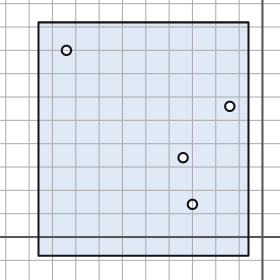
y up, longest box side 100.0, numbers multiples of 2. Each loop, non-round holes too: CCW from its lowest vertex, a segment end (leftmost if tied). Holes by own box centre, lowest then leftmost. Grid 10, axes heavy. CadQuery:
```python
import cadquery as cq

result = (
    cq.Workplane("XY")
    .moveTo(-96.0, -8.0)
    .lineTo(-6.0, -8.0)
    .lineTo(-6.0, 92.0)
    .lineTo(-96.0, 92.0)
    .close()
    .moveTo(-30.0, 14.0)
    .circle(2.0)
    .moveTo(-34.0, 34.0)
    .circle(2.0)
    .moveTo(-14.0, 56.0)
    .circle(2.0)
    .moveTo(-84.0, 80.0)
    .circle(2.0)
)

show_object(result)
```